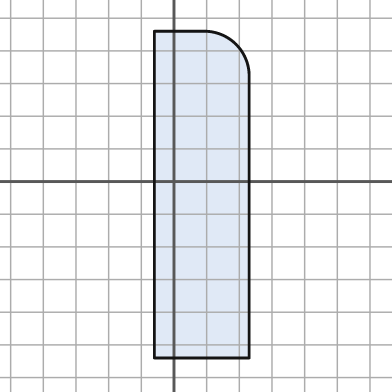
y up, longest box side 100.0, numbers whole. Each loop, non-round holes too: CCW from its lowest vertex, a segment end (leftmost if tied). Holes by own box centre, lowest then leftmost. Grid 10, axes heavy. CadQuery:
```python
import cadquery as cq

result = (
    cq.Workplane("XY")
    .moveTo(-6.0, -54.0)
    .lineTo(23.0, -54.0)
    .lineTo(23.0, 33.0)
    .threePointArc((19.0, 42.0), (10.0, 46.0))
    .lineTo(-6.0, 46.0)
    .close()
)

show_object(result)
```